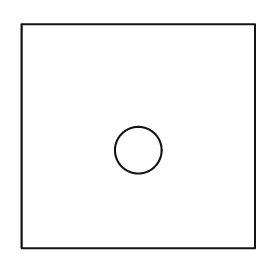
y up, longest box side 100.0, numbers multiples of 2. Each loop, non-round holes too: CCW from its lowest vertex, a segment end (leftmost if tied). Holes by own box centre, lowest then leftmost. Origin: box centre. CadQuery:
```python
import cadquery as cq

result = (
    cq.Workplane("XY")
    .moveTo(-50.0, -48.0)
    .lineTo(50.0, -48.0)
    .lineTo(50.0, 48.0)
    .lineTo(-50.0, 48.0)
    .close()
    .moveTo(0.0, -6.0)
    .circle(10.0)
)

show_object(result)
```